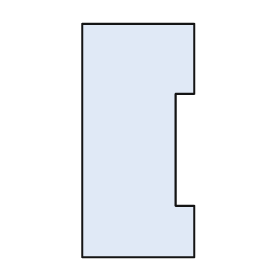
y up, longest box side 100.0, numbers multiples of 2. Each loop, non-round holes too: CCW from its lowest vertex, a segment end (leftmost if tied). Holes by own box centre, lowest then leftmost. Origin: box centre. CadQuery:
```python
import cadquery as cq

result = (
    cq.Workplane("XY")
    .moveTo(-24.0, -50.0)
    .lineTo(24.0, -50.0)
    .lineTo(24.0, -28.0)
    .lineTo(16.0, -28.0)
    .lineTo(16.0, 20.0)
    .lineTo(24.0, 20.0)
    .lineTo(24.0, 50.0)
    .lineTo(-24.0, 50.0)
    .close()
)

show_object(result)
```